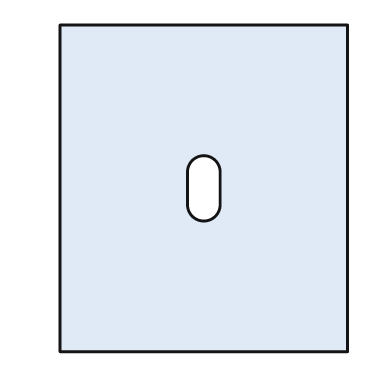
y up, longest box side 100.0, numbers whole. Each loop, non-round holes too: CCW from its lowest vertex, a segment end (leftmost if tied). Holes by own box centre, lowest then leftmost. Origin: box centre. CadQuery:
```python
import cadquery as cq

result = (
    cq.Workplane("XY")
    .moveTo(-44.0, -50.0)
    .lineTo(44.0, -50.0)
    .lineTo(44.0, 50.0)
    .lineTo(-44.0, 50.0)
    .close()
    .moveTo(-5.0, -5.0)
    .threePointArc((0.0, -10.0), (5.0, -5.0))
    .lineTo(5.0, 5.0)
    .threePointArc((0.0, 10.0), (-5.0, 5.0))
    .close()
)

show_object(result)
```